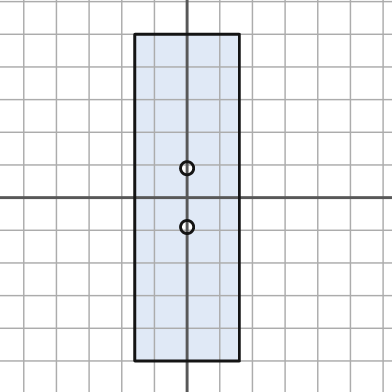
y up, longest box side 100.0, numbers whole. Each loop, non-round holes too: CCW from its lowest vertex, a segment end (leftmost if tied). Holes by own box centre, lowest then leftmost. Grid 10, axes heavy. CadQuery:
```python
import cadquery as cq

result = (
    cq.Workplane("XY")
    .moveTo(-16.0, -50.0)
    .lineTo(16.0, -50.0)
    .lineTo(16.0, 50.0)
    .lineTo(-16.0, 50.0)
    .close()
    .moveTo(0.0, -9.0)
    .circle(2.0)
    .moveTo(0.0, 9.0)
    .circle(2.0)
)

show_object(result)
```